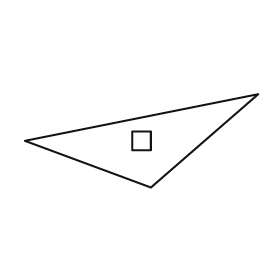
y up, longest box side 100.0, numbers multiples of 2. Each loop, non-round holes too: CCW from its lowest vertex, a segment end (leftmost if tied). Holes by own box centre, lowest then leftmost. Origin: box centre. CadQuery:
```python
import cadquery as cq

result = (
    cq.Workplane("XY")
    .moveTo(4.0, -20.0)
    .lineTo(50.0, 20.0)
    .lineTo(-50.0, 0.0)
    .close()
    .moveTo(-4.0, -4.0)
    .lineTo(4.0, -4.0)
    .lineTo(4.0, 4.0)
    .lineTo(-4.0, 4.0)
    .close()
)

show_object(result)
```